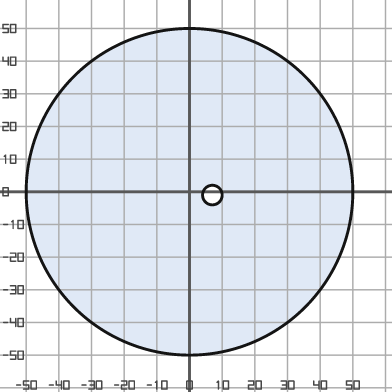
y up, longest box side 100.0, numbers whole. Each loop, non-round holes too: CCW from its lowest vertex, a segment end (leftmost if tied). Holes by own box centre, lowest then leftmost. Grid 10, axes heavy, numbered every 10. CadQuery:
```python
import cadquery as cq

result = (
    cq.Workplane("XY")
    .moveTo(0.0, 0.0)
    .circle(50.0)
    .moveTo(7.0, -1.0)
    .circle(3.0)
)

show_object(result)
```